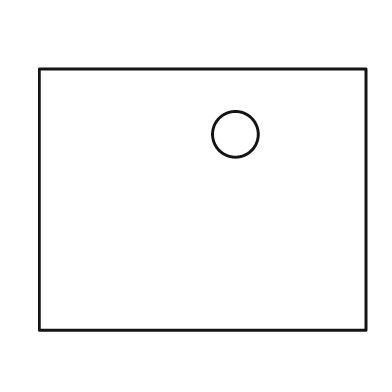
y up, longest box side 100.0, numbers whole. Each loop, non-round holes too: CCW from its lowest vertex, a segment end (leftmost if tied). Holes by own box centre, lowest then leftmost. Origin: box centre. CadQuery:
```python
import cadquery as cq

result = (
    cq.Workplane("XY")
    .moveTo(-50.0, -40.0)
    .lineTo(50.0, -40.0)
    .lineTo(50.0, 40.0)
    .lineTo(-50.0, 40.0)
    .close()
    .moveTo(10.0, 20.0)
    .circle(7.0)
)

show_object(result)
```